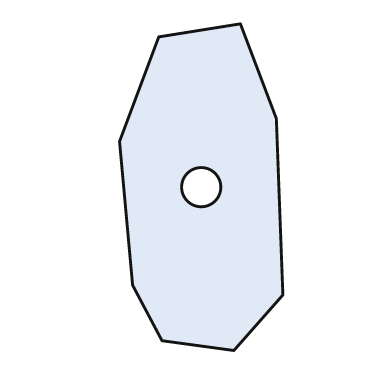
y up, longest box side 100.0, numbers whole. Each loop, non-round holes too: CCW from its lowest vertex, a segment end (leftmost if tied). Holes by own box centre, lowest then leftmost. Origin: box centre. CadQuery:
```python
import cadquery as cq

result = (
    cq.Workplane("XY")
    .moveTo(10.0, -50.0)
    .lineTo(25.0, -33.0)
    .lineTo(23.0, 21.0)
    .lineTo(12.0, 50.0)
    .lineTo(-13.0, 46.0)
    .lineTo(-25.0, 14.0)
    .lineTo(-21.0, -30.0)
    .lineTo(-12.0, -47.0)
    .close()
    .moveTo(0.0, 0.0)
    .circle(6.0)
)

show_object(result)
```